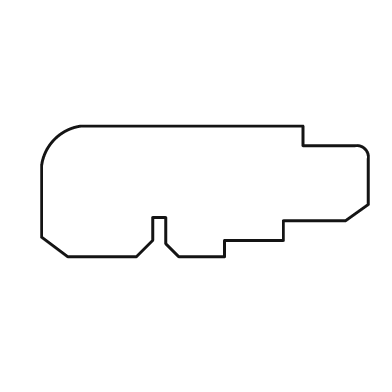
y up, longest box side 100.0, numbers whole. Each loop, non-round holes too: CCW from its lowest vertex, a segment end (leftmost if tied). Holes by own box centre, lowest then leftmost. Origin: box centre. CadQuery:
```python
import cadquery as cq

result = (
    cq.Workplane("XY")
    .moveTo(-42.0, -20.0)
    .lineTo(-21.0, -20.0)
    .lineTo(-16.0, -15.0)
    .lineTo(-16.0, -8.0)
    .lineTo(-12.0, -8.0)
    .lineTo(-12.0, -16.0)
    .lineTo(-8.0, -20.0)
    .lineTo(6.0, -20.0)
    .lineTo(6.0, -15.0)
    .lineTo(24.0, -15.0)
    .lineTo(24.0, -9.0)
    .lineTo(43.0, -9.0)
    .lineTo(50.0, -4.0)
    .lineTo(50.0, 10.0)
    .threePointArc((49.0, 13.0), (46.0, 14.0))
    .lineTo(30.0, 14.0)
    .lineTo(30.0, 20.0)
    .lineTo(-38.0, 20.0)
    .threePointArc((-46.0, 16.0), (-50.0, 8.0))
    .lineTo(-50.0, -14.0)
    .close()
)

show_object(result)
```